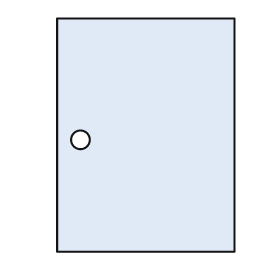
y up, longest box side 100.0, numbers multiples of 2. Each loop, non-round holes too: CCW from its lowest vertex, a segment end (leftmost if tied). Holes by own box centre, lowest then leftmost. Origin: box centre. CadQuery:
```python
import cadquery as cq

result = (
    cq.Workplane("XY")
    .moveTo(-38.0, -50.0)
    .lineTo(38.0, -50.0)
    .lineTo(38.0, 50.0)
    .lineTo(-38.0, 50.0)
    .close()
    .moveTo(-28.0, -2.0)
    .circle(4.0)
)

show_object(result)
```